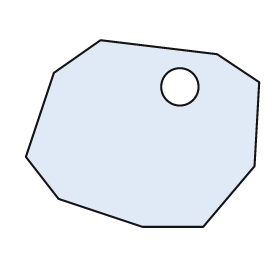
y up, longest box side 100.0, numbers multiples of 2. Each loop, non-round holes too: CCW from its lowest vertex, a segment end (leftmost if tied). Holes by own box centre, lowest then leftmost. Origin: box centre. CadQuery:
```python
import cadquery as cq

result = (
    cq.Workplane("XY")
    .moveTo(0.0, -40.0)
    .lineTo(26.0, -40.0)
    .lineTo(48.0, -14.0)
    .lineTo(50.0, 22.0)
    .lineTo(32.0, 34.0)
    .lineTo(-18.0, 40.0)
    .lineTo(-38.0, 26.0)
    .lineTo(-50.0, -10.0)
    .lineTo(-36.0, -28.0)
    .close()
    .moveTo(16.0, 20.0)
    .circle(8.0)
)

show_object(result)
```